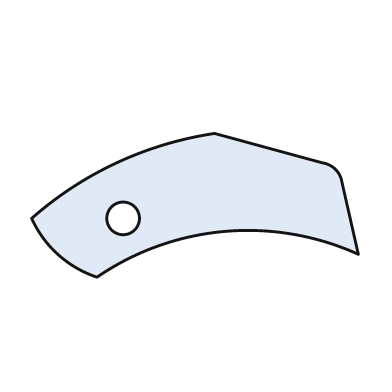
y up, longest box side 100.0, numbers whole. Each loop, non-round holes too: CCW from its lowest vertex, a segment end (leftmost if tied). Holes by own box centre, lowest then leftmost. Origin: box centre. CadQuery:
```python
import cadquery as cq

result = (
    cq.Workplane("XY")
    .moveTo(-30.0, -22.0)
    .threePointArc((9.0, -8.0), (50.0, -15.0))
    .lineTo(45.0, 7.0)
    .threePointArc((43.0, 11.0), (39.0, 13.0))
    .lineTo(6.0, 22.0)
    .threePointArc((-24.0, 13.0), (-50.0, -4.0))
    .threePointArc((-42.0, -15.0), (-30.0, -22.0))
    .close()
    .moveTo(-22.0, -4.0)
    .circle(5.0)
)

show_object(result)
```